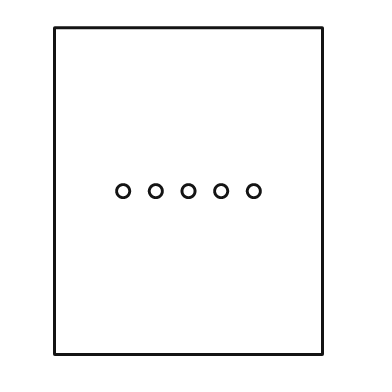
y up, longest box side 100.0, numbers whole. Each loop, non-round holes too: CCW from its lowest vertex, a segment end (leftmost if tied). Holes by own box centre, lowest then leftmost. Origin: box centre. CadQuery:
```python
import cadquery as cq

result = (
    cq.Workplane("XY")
    .moveTo(-41.0, -50.0)
    .lineTo(41.0, -50.0)
    .lineTo(41.0, 50.0)
    .lineTo(-41.0, 50.0)
    .close()
    .moveTo(-20.0, 0.0)
    .circle(2.0)
    .moveTo(-10.0, 0.0)
    .circle(2.0)
    .moveTo(0.0, 0.0)
    .circle(2.0)
    .moveTo(10.0, 0.0)
    .circle(2.0)
    .moveTo(20.0, 0.0)
    .circle(2.0)
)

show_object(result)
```